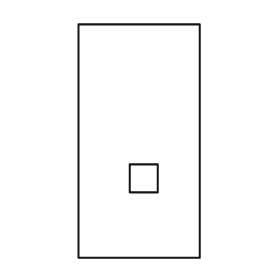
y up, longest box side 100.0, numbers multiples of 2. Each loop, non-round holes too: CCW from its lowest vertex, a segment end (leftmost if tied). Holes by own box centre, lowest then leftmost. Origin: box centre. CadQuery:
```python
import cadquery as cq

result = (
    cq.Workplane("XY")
    .moveTo(-26.0, -50.0)
    .lineTo(26.0, -50.0)
    .lineTo(26.0, 50.0)
    .lineTo(-26.0, 50.0)
    .close()
    .moveTo(-4.0, -22.0)
    .lineTo(8.0, -22.0)
    .lineTo(8.0, -10.0)
    .lineTo(-4.0, -10.0)
    .close()
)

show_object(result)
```